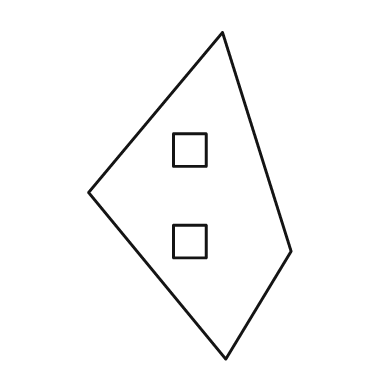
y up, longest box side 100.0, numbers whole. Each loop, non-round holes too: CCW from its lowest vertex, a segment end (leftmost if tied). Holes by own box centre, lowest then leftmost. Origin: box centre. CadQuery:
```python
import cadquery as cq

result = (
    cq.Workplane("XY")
    .moveTo(11.0, -50.0)
    .lineTo(31.0, -17.0)
    .lineTo(10.0, 50.0)
    .lineTo(-31.0, 1.0)
    .close()
    .moveTo(-5.0, -19.0)
    .lineTo(5.0, -19.0)
    .lineTo(5.0, -9.0)
    .lineTo(-5.0, -9.0)
    .close()
    .moveTo(-5.0, 9.0)
    .lineTo(5.0, 9.0)
    .lineTo(5.0, 19.0)
    .lineTo(-5.0, 19.0)
    .close()
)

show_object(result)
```